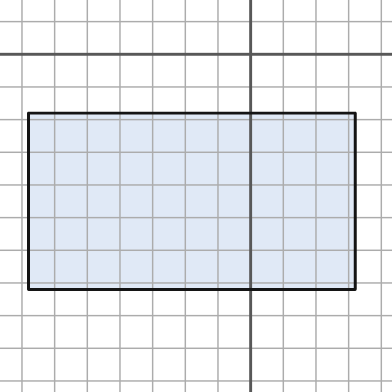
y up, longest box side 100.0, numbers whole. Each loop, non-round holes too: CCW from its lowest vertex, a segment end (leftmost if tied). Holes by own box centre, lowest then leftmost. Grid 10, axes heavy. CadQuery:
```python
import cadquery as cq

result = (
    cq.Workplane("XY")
    .moveTo(-68.0, -72.0)
    .lineTo(32.0, -72.0)
    .lineTo(32.0, -18.0)
    .lineTo(-68.0, -18.0)
    .close()
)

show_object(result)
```